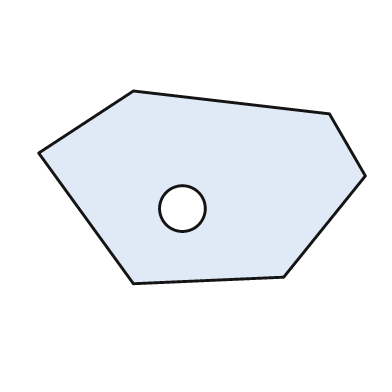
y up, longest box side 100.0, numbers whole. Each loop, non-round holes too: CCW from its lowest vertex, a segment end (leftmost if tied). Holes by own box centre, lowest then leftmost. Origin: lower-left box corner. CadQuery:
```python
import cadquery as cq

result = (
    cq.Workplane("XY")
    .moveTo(29.0, 0.0)
    .lineTo(75.0, 2.0)
    .lineTo(100.0, 33.0)
    .lineTo(89.0, 52.0)
    .lineTo(29.0, 59.0)
    .lineTo(0.0, 40.0)
    .close()
    .moveTo(44.0, 23.0)
    .circle(7.0)
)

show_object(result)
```